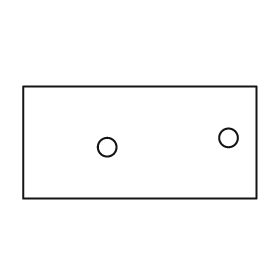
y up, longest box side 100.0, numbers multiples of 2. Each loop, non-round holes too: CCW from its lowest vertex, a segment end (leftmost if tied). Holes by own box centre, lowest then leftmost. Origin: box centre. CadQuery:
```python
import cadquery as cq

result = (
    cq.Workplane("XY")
    .moveTo(-50.0, -24.0)
    .lineTo(50.0, -24.0)
    .lineTo(50.0, 24.0)
    .lineTo(-50.0, 24.0)
    .close()
    .moveTo(-14.0, -2.0)
    .circle(4.0)
    .moveTo(38.0, 2.0)
    .circle(4.0)
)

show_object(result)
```